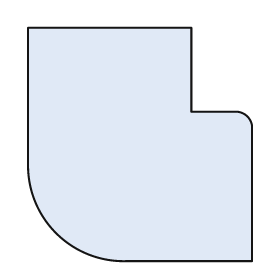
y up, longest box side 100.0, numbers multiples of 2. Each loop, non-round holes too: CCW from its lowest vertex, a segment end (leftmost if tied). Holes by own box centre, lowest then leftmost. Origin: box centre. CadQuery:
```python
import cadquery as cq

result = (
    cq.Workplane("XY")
    .moveTo(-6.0, -50.0)
    .lineTo(48.0, -50.0)
    .lineTo(48.0, 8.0)
    .threePointArc((46.0, 12.0), (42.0, 14.0))
    .lineTo(22.0, 14.0)
    .lineTo(22.0, 50.0)
    .lineTo(-48.0, 50.0)
    .lineTo(-48.0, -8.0)
    .threePointArc((-36.0, -38.0), (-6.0, -50.0))
    .close()
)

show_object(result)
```